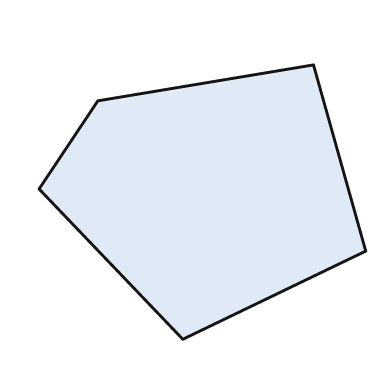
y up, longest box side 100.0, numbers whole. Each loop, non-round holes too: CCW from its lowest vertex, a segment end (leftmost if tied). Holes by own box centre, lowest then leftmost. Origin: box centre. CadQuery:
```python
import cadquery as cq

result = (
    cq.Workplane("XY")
    .moveTo(-6.0, -42.0)
    .lineTo(50.0, -15.0)
    .lineTo(34.0, 42.0)
    .lineTo(-32.0, 31.0)
    .lineTo(-50.0, 4.0)
    .close()
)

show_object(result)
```